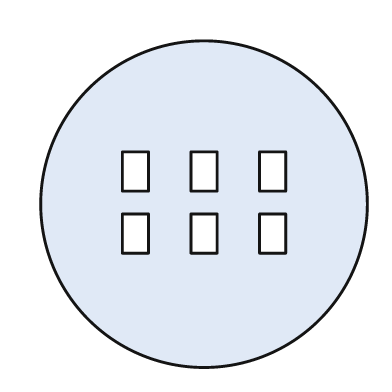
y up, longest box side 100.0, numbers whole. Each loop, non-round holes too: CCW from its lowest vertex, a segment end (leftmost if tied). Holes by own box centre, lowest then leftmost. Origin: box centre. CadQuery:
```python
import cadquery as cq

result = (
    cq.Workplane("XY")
    .moveTo(0.0, 0.0)
    .circle(50.0)
    .moveTo(-25.0, -15.0)
    .lineTo(-17.0, -15.0)
    .lineTo(-17.0, -3.0)
    .lineTo(-25.0, -3.0)
    .close()
    .moveTo(-4.0, -15.0)
    .lineTo(4.0, -15.0)
    .lineTo(4.0, -3.0)
    .lineTo(-4.0, -3.0)
    .close()
    .moveTo(17.0, -15.0)
    .lineTo(25.0, -15.0)
    .lineTo(25.0, -3.0)
    .lineTo(17.0, -3.0)
    .close()
    .moveTo(-25.0, 4.0)
    .lineTo(-17.0, 4.0)
    .lineTo(-17.0, 16.0)
    .lineTo(-25.0, 16.0)
    .close()
    .moveTo(-4.0, 4.0)
    .lineTo(4.0, 4.0)
    .lineTo(4.0, 16.0)
    .lineTo(-4.0, 16.0)
    .close()
    .moveTo(17.0, 4.0)
    .lineTo(25.0, 4.0)
    .lineTo(25.0, 16.0)
    .lineTo(17.0, 16.0)
    .close()
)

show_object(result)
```